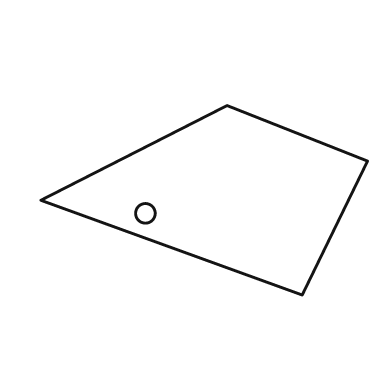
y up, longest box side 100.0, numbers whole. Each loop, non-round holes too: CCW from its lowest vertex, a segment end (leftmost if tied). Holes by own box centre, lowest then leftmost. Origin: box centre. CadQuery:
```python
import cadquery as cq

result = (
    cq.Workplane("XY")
    .moveTo(30.0, -29.0)
    .lineTo(50.0, 12.0)
    .lineTo(7.0, 29.0)
    .lineTo(-50.0, 0.0)
    .close()
    .moveTo(-18.0, -4.0)
    .circle(3.0)
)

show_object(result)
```